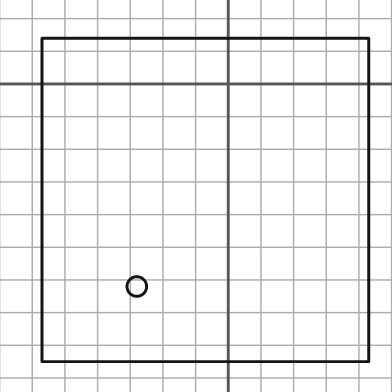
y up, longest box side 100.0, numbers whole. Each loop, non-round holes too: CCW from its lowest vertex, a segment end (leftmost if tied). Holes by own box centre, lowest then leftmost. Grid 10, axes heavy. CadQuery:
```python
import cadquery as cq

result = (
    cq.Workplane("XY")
    .moveTo(-57.0, -85.0)
    .lineTo(43.0, -85.0)
    .lineTo(43.0, 14.0)
    .lineTo(-57.0, 14.0)
    .close()
    .moveTo(-28.0, -62.0)
    .circle(3.0)
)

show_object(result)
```